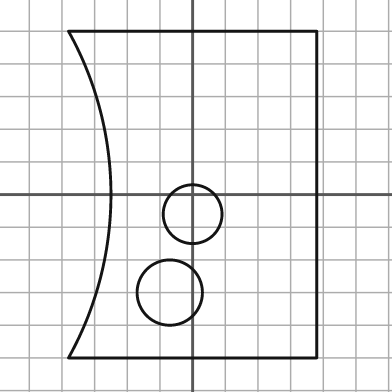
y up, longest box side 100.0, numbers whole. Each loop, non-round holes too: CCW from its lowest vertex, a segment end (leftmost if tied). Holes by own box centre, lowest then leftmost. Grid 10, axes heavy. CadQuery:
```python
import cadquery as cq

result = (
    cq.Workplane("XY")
    .moveTo(-38.0, -50.0)
    .lineTo(38.0, -50.0)
    .lineTo(38.0, 50.0)
    .lineTo(-38.0, 50.0)
    .threePointArc((-25.0, 0.0), (-38.0, -50.0))
    .close()
    .moveTo(-7.0, -30.0)
    .circle(10.0)
    .moveTo(0.0, -6.0)
    .circle(9.0)
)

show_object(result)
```